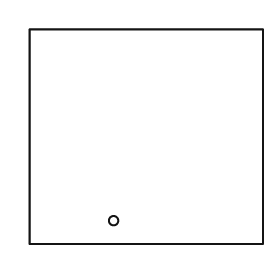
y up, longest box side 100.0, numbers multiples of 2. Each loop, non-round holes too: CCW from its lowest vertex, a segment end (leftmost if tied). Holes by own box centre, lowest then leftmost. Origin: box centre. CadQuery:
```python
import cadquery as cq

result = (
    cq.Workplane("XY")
    .moveTo(-50.0, -46.0)
    .lineTo(50.0, -46.0)
    .lineTo(50.0, 46.0)
    .lineTo(-50.0, 46.0)
    .close()
    .moveTo(-14.0, -36.0)
    .circle(2.0)
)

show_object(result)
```